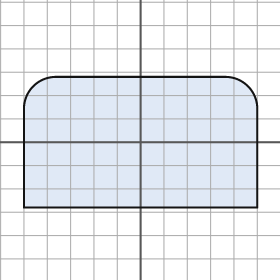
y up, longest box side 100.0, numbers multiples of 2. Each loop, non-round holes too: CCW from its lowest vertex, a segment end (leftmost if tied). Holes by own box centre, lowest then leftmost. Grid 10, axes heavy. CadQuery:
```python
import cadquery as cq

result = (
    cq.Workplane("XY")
    .moveTo(-50.0, -28.0)
    .lineTo(50.0, -28.0)
    .lineTo(50.0, 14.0)
    .threePointArc((46.0, 24.0), (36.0, 28.0))
    .lineTo(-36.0, 28.0)
    .threePointArc((-46.0, 24.0), (-50.0, 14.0))
    .close()
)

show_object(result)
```